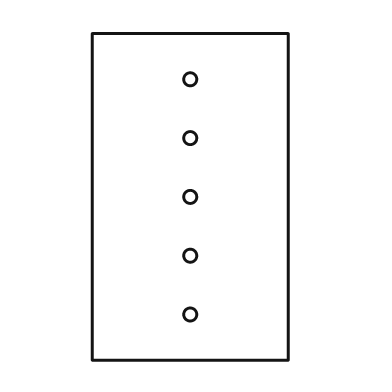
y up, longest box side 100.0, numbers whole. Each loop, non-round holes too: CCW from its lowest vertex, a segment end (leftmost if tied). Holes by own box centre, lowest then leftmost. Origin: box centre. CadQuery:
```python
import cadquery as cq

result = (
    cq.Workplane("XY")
    .moveTo(-30.0, -50.0)
    .lineTo(30.0, -50.0)
    .lineTo(30.0, 50.0)
    .lineTo(-30.0, 50.0)
    .close()
    .moveTo(0.0, -36.0)
    .circle(2.0)
    .moveTo(0.0, -18.0)
    .circle(2.0)
    .moveTo(0.0, 0.0)
    .circle(2.0)
    .moveTo(0.0, 18.0)
    .circle(2.0)
    .moveTo(0.0, 36.0)
    .circle(2.0)
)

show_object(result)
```